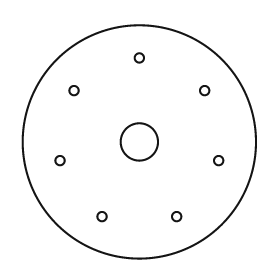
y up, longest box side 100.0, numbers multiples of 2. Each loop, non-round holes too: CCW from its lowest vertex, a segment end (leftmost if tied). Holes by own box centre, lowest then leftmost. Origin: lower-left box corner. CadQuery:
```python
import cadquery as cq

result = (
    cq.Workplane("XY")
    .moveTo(50.0, 50.0)
    .circle(50.0)
    .moveTo(34.0, 18.0)
    .circle(2.0)
    .moveTo(66.0, 18.0)
    .circle(2.0)
    .moveTo(16.0, 42.0)
    .circle(2.0)
    .moveTo(84.0, 42.0)
    .circle(2.0)
    .moveTo(50.0, 50.0)
    .circle(8.0)
    .moveTo(22.0, 72.0)
    .circle(2.0)
    .moveTo(78.0, 72.0)
    .circle(2.0)
    .moveTo(50.0, 86.0)
    .circle(2.0)
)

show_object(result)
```